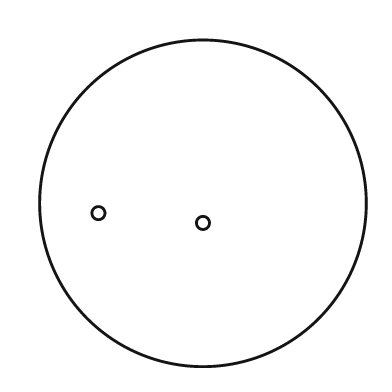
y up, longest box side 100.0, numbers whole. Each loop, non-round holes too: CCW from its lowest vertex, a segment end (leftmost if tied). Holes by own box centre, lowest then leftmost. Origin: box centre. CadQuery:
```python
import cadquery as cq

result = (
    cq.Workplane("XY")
    .moveTo(0.0, 0.0)
    .circle(50.0)
    .moveTo(0.0, -6.0)
    .circle(2.0)
    .moveTo(-32.0, -3.0)
    .circle(2.0)
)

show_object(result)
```